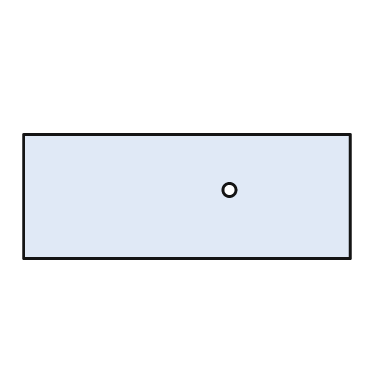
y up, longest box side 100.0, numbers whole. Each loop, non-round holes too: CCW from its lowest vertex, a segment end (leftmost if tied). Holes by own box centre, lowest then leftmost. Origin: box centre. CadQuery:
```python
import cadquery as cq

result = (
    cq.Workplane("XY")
    .moveTo(-50.0, -19.0)
    .lineTo(50.0, -19.0)
    .lineTo(50.0, 19.0)
    .lineTo(-50.0, 19.0)
    .close()
    .moveTo(13.0, 2.0)
    .circle(2.0)
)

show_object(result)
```